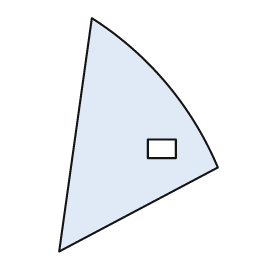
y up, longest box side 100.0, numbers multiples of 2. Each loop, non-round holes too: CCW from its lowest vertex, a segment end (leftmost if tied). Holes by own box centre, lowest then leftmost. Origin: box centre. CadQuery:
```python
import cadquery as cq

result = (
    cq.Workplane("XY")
    .moveTo(-34.0, -50.0)
    .lineTo(34.0, -14.0)
    .threePointArc((12.0, 22.0), (-20.0, 50.0))
    .close()
    .moveTo(4.0, -10.0)
    .lineTo(16.0, -10.0)
    .lineTo(16.0, -2.0)
    .lineTo(4.0, -2.0)
    .close()
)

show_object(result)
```